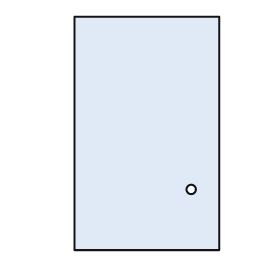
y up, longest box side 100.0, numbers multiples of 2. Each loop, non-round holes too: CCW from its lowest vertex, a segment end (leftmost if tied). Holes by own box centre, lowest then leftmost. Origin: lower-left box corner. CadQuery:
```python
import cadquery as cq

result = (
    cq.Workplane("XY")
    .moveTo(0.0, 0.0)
    .lineTo(62.0, 0.0)
    .lineTo(62.0, 100.0)
    .lineTo(0.0, 100.0)
    .close()
    .moveTo(50.0, 26.0)
    .circle(2.0)
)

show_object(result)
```